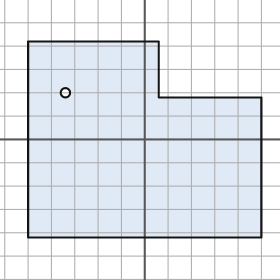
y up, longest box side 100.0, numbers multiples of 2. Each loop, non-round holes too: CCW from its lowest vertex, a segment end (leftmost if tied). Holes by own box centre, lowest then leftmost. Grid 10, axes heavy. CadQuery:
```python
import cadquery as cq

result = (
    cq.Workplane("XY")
    .moveTo(-50.0, -42.0)
    .lineTo(50.0, -42.0)
    .lineTo(50.0, 18.0)
    .lineTo(6.0, 18.0)
    .lineTo(6.0, 42.0)
    .lineTo(-50.0, 42.0)
    .close()
    .moveTo(-34.0, 20.0)
    .circle(2.0)
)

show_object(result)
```